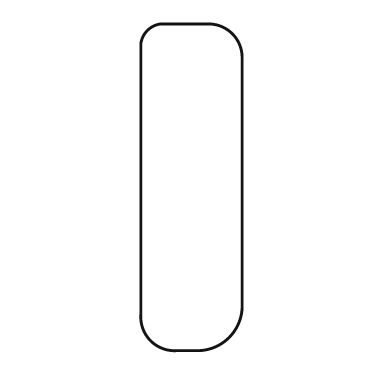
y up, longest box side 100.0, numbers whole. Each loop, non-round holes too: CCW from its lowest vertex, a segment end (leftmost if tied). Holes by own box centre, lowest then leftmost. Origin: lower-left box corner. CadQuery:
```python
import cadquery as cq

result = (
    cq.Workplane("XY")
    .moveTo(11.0, 0.0)
    .lineTo(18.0, 0.0)
    .threePointArc((27.0, 4.0), (31.0, 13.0))
    .lineTo(31.0, 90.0)
    .threePointArc((28.0, 97.0), (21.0, 100.0))
    .lineTo(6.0, 100.0)
    .threePointArc((2.0, 98.0), (0.0, 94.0))
    .lineTo(0.0, 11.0)
    .threePointArc((3.0, 3.0), (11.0, 0.0))
    .close()
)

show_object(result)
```